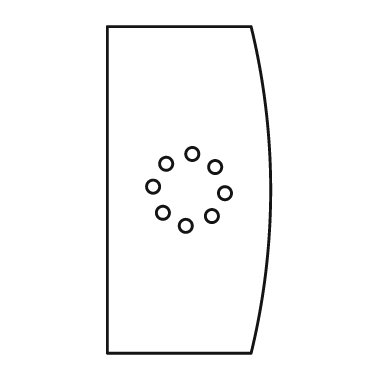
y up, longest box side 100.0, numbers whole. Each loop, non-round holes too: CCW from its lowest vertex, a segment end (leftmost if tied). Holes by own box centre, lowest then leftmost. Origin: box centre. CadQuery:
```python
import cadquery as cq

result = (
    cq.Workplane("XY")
    .moveTo(-25.0, -50.0)
    .lineTo(19.0, -50.0)
    .threePointArc((25.0, 0.0), (19.0, 50.0))
    .lineTo(-25.0, 50.0)
    .close()
    .moveTo(-1.0, -11.0)
    .circle(2.0)
    .moveTo(7.0, -8.0)
    .circle(2.0)
    .moveTo(-8.0, -7.0)
    .circle(2.0)
    .moveTo(11.0, -1.0)
    .circle(2.0)
    .moveTo(-11.0, 1.0)
    .circle(2.0)
    .moveTo(8.0, 7.0)
    .circle(2.0)
    .moveTo(-7.0, 8.0)
    .circle(2.0)
    .moveTo(1.0, 11.0)
    .circle(2.0)
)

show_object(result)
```